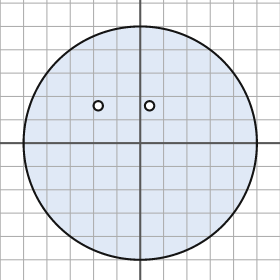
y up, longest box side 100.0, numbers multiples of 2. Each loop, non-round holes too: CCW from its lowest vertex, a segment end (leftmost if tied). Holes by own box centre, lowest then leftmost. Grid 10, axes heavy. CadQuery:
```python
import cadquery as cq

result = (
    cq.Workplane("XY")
    .moveTo(0.0, 0.0)
    .circle(50.0)
    .moveTo(-18.0, 16.0)
    .circle(2.0)
    .moveTo(4.0, 16.0)
    .circle(2.0)
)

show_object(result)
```